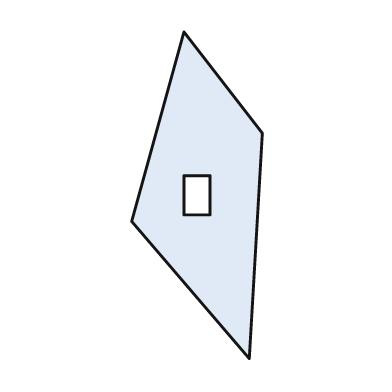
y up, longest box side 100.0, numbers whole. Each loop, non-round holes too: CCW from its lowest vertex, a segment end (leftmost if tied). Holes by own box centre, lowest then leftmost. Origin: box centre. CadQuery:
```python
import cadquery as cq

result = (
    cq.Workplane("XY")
    .moveTo(16.0, -50.0)
    .lineTo(20.0, 19.0)
    .lineTo(-4.0, 50.0)
    .lineTo(-20.0, -8.0)
    .close()
    .moveTo(-4.0, -6.0)
    .lineTo(4.0, -6.0)
    .lineTo(4.0, 6.0)
    .lineTo(-4.0, 6.0)
    .close()
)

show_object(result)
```